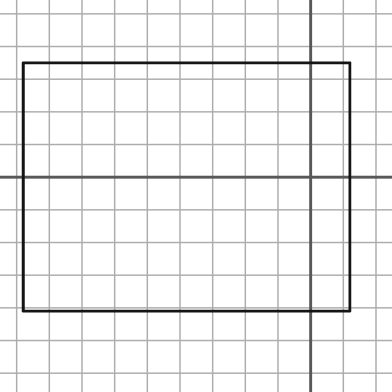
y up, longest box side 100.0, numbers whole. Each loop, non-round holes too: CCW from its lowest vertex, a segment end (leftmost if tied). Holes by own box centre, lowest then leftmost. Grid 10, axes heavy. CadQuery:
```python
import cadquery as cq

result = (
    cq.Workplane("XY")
    .moveTo(-88.0, -41.0)
    .lineTo(12.0, -41.0)
    .lineTo(12.0, 35.0)
    .lineTo(-88.0, 35.0)
    .close()
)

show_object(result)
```